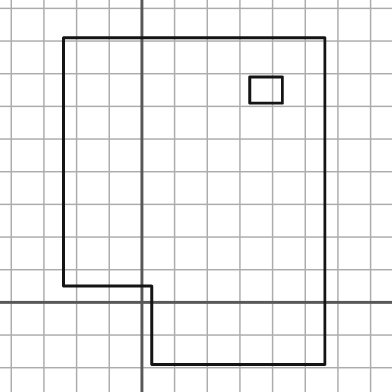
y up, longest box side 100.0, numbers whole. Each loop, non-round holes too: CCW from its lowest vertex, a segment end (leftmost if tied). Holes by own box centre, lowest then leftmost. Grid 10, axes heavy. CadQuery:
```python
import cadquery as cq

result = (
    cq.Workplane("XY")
    .moveTo(3.0, -19.0)
    .lineTo(56.0, -19.0)
    .lineTo(56.0, 81.0)
    .lineTo(-24.0, 81.0)
    .lineTo(-24.0, 5.0)
    .lineTo(3.0, 5.0)
    .close()
    .moveTo(33.0, 61.0)
    .lineTo(43.0, 61.0)
    .lineTo(43.0, 69.0)
    .lineTo(33.0, 69.0)
    .close()
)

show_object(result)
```